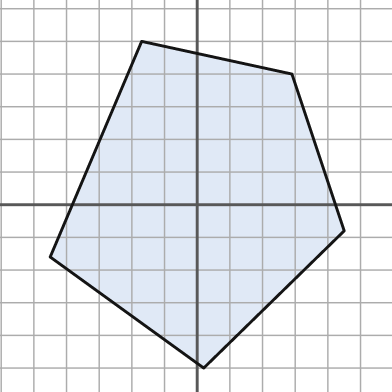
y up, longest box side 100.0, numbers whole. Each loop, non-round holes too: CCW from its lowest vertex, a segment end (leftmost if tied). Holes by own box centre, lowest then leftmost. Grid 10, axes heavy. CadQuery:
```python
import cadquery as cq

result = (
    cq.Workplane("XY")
    .moveTo(2.0, -50.0)
    .lineTo(45.0, -8.0)
    .lineTo(29.0, 40.0)
    .lineTo(-17.0, 50.0)
    .lineTo(-45.0, -16.0)
    .close()
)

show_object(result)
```